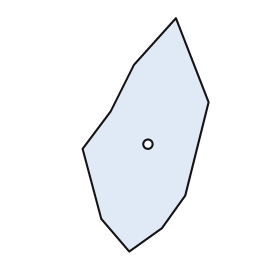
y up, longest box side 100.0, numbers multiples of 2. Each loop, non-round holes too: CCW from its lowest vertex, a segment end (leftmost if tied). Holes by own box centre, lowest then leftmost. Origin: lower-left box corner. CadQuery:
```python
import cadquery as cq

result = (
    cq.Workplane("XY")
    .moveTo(20.0, 0.0)
    .lineTo(34.0, 10.0)
    .lineTo(44.0, 24.0)
    .lineTo(54.0, 64.0)
    .lineTo(40.0, 100.0)
    .lineTo(22.0, 80.0)
    .lineTo(12.0, 60.0)
    .lineTo(0.0, 44.0)
    .lineTo(8.0, 14.0)
    .close()
    .moveTo(28.0, 46.0)
    .circle(2.0)
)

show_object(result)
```